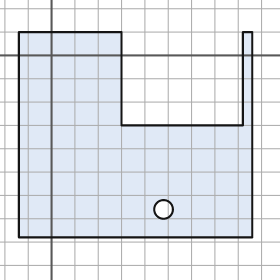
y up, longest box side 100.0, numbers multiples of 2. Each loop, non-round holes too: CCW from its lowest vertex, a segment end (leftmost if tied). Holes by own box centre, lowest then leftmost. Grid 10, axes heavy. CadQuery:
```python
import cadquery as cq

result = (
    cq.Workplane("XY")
    .moveTo(-14.0, -78.0)
    .lineTo(86.0, -78.0)
    .lineTo(86.0, 10.0)
    .lineTo(82.0, 10.0)
    .lineTo(82.0, -30.0)
    .lineTo(30.0, -30.0)
    .lineTo(30.0, 10.0)
    .lineTo(-14.0, 10.0)
    .close()
    .moveTo(48.0, -66.0)
    .circle(4.0)
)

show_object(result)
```